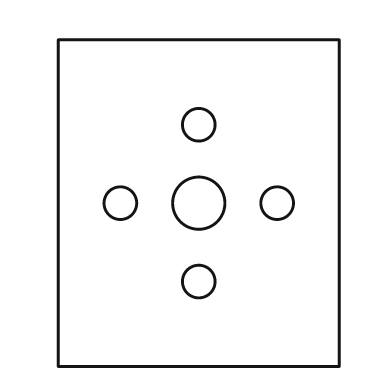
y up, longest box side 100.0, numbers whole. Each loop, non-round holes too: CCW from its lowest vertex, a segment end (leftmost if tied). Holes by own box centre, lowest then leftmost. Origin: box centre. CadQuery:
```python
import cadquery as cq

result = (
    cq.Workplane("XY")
    .moveTo(-43.0, -50.0)
    .lineTo(43.0, -50.0)
    .lineTo(43.0, 50.0)
    .lineTo(-43.0, 50.0)
    .close()
    .moveTo(0.0, -24.0)
    .circle(5.0)
    .moveTo(-24.0, 0.0)
    .circle(5.0)
    .moveTo(0.0, 0.0)
    .circle(8.0)
    .moveTo(24.0, 0.0)
    .circle(5.0)
    .moveTo(0.0, 24.0)
    .circle(5.0)
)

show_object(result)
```